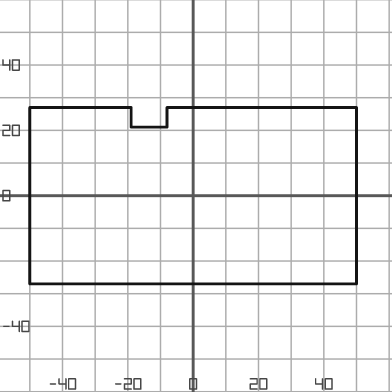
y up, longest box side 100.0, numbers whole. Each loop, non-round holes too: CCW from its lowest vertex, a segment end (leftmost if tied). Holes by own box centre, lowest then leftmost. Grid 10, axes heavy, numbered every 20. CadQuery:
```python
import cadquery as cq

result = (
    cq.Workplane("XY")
    .moveTo(-50.0, -27.0)
    .lineTo(50.0, -27.0)
    .lineTo(50.0, 27.0)
    .lineTo(-8.0, 27.0)
    .lineTo(-8.0, 21.0)
    .lineTo(-19.0, 21.0)
    .lineTo(-19.0, 27.0)
    .lineTo(-50.0, 27.0)
    .close()
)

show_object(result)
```